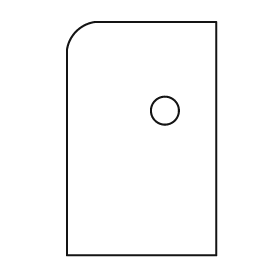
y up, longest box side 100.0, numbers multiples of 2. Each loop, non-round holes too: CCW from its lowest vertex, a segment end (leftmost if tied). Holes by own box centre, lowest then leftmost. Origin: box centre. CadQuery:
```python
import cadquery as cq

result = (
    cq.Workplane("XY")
    .moveTo(-32.0, -50.0)
    .lineTo(32.0, -50.0)
    .lineTo(32.0, 50.0)
    .lineTo(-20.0, 50.0)
    .threePointArc((-28.0, 46.0), (-32.0, 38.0))
    .close()
    .moveTo(10.0, 12.0)
    .circle(6.0)
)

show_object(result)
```